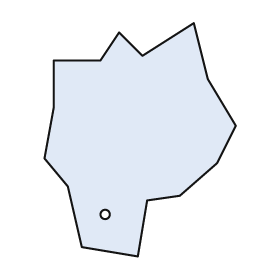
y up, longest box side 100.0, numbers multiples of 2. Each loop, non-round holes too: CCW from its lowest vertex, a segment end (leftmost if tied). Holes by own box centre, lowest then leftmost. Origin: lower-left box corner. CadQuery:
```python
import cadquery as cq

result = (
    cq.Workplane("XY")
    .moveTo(40.0, 0.0)
    .lineTo(44.0, 24.0)
    .lineTo(58.0, 26.0)
    .lineTo(74.0, 40.0)
    .lineTo(82.0, 56.0)
    .lineTo(70.0, 76.0)
    .lineTo(64.0, 100.0)
    .lineTo(42.0, 86.0)
    .lineTo(32.0, 96.0)
    .lineTo(24.0, 84.0)
    .lineTo(4.0, 84.0)
    .lineTo(4.0, 64.0)
    .lineTo(0.0, 42.0)
    .lineTo(10.0, 30.0)
    .lineTo(16.0, 4.0)
    .close()
    .moveTo(26.0, 18.0)
    .circle(2.0)
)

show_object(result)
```